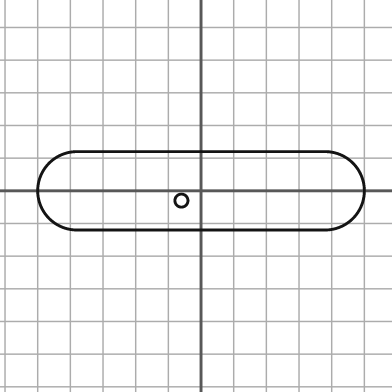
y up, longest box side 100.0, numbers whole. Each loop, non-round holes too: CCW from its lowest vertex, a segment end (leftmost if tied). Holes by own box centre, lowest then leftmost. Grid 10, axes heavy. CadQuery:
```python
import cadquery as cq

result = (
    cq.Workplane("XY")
    .moveTo(-38.0, -12.0)
    .lineTo(38.0, -12.0)
    .threePointArc((50.0, 0.0), (38.0, 12.0))
    .lineTo(-38.0, 12.0)
    .threePointArc((-50.0, 0.0), (-38.0, -12.0))
    .close()
    .moveTo(-6.0, -3.0)
    .circle(2.0)
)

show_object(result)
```